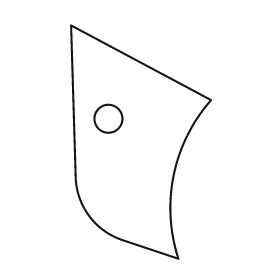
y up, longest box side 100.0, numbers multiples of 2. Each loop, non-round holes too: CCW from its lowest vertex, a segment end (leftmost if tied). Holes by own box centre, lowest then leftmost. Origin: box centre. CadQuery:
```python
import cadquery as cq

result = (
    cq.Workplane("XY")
    .moveTo(16.0, -50.0)
    .threePointArc((14.0, -14.0), (30.0, 18.0))
    .lineTo(-30.0, 50.0)
    .lineTo(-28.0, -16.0)
    .threePointArc((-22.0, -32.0), (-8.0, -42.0))
    .close()
    .moveTo(-14.0, 10.0)
    .circle(6.0)
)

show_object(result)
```